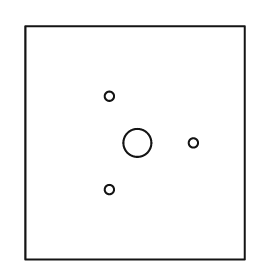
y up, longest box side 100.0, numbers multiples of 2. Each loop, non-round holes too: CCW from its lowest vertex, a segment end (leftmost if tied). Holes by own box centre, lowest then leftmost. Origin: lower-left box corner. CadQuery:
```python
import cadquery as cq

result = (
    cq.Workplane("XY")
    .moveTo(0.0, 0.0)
    .lineTo(94.0, 0.0)
    .lineTo(94.0, 100.0)
    .lineTo(0.0, 100.0)
    .close()
    .moveTo(36.0, 30.0)
    .circle(2.0)
    .moveTo(48.0, 50.0)
    .circle(6.0)
    .moveTo(72.0, 50.0)
    .circle(2.0)
    .moveTo(36.0, 70.0)
    .circle(2.0)
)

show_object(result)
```